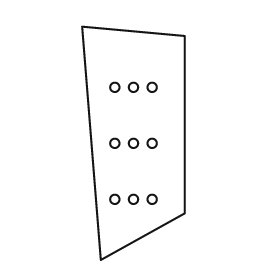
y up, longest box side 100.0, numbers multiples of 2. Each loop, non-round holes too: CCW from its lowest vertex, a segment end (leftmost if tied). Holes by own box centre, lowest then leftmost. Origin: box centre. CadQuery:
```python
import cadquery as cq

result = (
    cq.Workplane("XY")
    .moveTo(-14.0, -50.0)
    .lineTo(22.0, -30.0)
    .lineTo(22.0, 46.0)
    .lineTo(-22.0, 50.0)
    .close()
    .moveTo(-8.0, -24.0)
    .circle(2.0)
    .moveTo(0.0, -24.0)
    .circle(2.0)
    .moveTo(8.0, -24.0)
    .circle(2.0)
    .moveTo(-8.0, 0.0)
    .circle(2.0)
    .moveTo(0.0, 0.0)
    .circle(2.0)
    .moveTo(8.0, 0.0)
    .circle(2.0)
    .moveTo(-8.0, 24.0)
    .circle(2.0)
    .moveTo(0.0, 24.0)
    .circle(2.0)
    .moveTo(8.0, 24.0)
    .circle(2.0)
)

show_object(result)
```